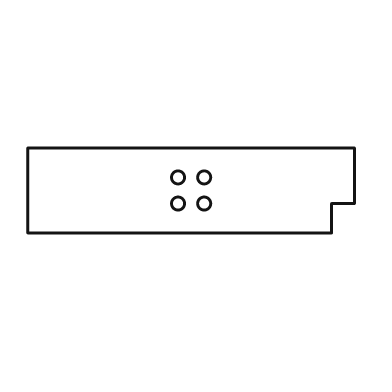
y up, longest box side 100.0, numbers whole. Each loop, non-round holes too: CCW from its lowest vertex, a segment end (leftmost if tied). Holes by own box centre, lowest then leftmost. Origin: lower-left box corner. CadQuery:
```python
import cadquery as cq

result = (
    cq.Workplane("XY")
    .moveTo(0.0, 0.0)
    .lineTo(93.0, 0.0)
    .lineTo(93.0, 9.0)
    .lineTo(100.0, 9.0)
    .lineTo(100.0, 26.0)
    .lineTo(0.0, 26.0)
    .close()
    .moveTo(46.0, 9.0)
    .circle(2.0)
    .moveTo(54.0, 9.0)
    .circle(2.0)
    .moveTo(46.0, 17.0)
    .circle(2.0)
    .moveTo(54.0, 17.0)
    .circle(2.0)
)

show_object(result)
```